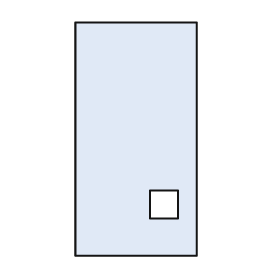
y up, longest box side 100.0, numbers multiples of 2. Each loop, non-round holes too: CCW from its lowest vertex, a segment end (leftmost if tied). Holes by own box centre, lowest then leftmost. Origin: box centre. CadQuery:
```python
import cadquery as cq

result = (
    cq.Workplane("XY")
    .moveTo(-26.0, -50.0)
    .lineTo(26.0, -50.0)
    .lineTo(26.0, 50.0)
    .lineTo(-26.0, 50.0)
    .close()
    .moveTo(6.0, -34.0)
    .lineTo(18.0, -34.0)
    .lineTo(18.0, -22.0)
    .lineTo(6.0, -22.0)
    .close()
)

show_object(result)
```